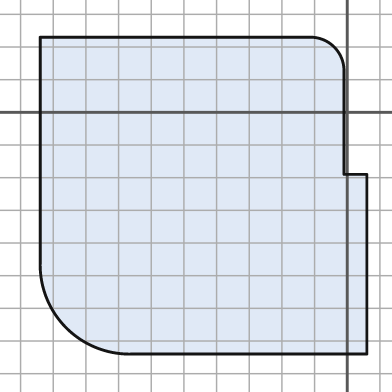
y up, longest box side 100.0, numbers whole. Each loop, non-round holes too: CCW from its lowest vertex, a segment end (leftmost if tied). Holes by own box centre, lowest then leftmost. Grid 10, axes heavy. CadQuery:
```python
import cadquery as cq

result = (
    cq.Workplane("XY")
    .moveTo(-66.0, -74.0)
    .lineTo(6.0, -74.0)
    .lineTo(6.0, -19.0)
    .lineTo(-1.0, -19.0)
    .lineTo(-1.0, 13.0)
    .threePointArc((-4.0, 20.0), (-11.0, 23.0))
    .lineTo(-94.0, 23.0)
    .lineTo(-94.0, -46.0)
    .threePointArc((-86.0, -66.0), (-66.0, -74.0))
    .close()
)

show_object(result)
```